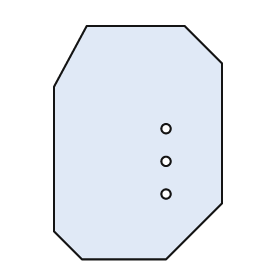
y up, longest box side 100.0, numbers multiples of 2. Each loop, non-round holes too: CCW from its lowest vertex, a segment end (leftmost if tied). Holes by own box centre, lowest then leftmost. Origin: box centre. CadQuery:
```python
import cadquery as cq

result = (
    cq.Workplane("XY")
    .moveTo(-24.0, -50.0)
    .lineTo(12.0, -50.0)
    .lineTo(36.0, -26.0)
    .lineTo(36.0, 34.0)
    .lineTo(20.0, 50.0)
    .lineTo(-22.0, 50.0)
    .lineTo(-36.0, 24.0)
    .lineTo(-36.0, -38.0)
    .close()
    .moveTo(12.0, -22.0)
    .circle(2.0)
    .moveTo(12.0, -8.0)
    .circle(2.0)
    .moveTo(12.0, 6.0)
    .circle(2.0)
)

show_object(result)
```